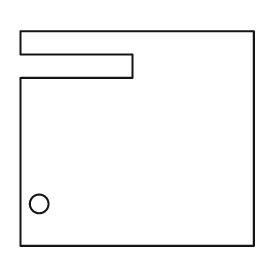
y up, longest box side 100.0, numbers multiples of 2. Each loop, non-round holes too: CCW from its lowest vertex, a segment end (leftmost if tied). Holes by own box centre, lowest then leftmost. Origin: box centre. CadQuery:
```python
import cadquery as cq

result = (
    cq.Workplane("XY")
    .moveTo(-50.0, -46.0)
    .lineTo(50.0, -46.0)
    .lineTo(50.0, 46.0)
    .lineTo(-50.0, 46.0)
    .lineTo(-50.0, 36.0)
    .lineTo(-2.0, 36.0)
    .lineTo(-2.0, 26.0)
    .lineTo(-50.0, 26.0)
    .close()
    .moveTo(-42.0, -28.0)
    .circle(4.0)
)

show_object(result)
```